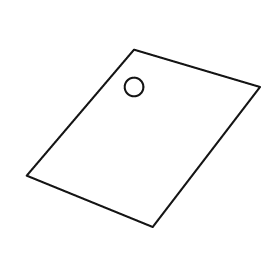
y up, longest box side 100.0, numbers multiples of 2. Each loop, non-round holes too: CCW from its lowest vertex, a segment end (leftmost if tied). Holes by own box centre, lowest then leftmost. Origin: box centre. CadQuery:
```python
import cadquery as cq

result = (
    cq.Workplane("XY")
    .moveTo(4.0, -38.0)
    .lineTo(50.0, 22.0)
    .lineTo(-4.0, 38.0)
    .lineTo(-50.0, -16.0)
    .close()
    .moveTo(-4.0, 22.0)
    .circle(4.0)
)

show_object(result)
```